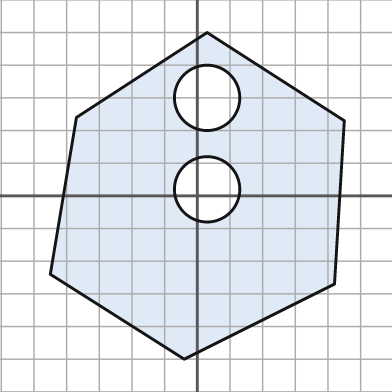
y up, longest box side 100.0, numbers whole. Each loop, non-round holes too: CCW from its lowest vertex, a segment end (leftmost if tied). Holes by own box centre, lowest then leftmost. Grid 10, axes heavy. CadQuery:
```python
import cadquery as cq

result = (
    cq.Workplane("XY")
    .moveTo(-4.0, -50.0)
    .lineTo(42.0, -27.0)
    .lineTo(45.0, 23.0)
    .lineTo(3.0, 50.0)
    .lineTo(-37.0, 24.0)
    .lineTo(-45.0, -24.0)
    .close()
    .moveTo(3.0, 2.0)
    .circle(10.0)
    .moveTo(3.0, 30.0)
    .circle(10.0)
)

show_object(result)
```